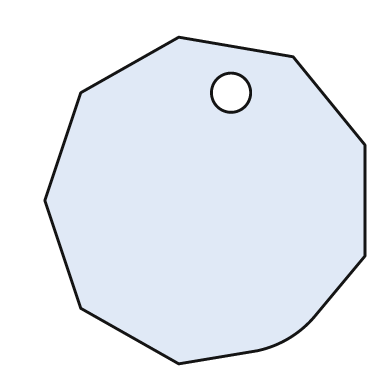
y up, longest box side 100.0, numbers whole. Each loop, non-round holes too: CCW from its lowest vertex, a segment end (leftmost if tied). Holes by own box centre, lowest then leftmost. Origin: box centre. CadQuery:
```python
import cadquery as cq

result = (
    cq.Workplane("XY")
    .moveTo(-8.0, -50.0)
    .lineTo(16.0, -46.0)
    .threePointArc((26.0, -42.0), (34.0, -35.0))
    .lineTo(49.0, -17.0)
    .lineTo(49.0, 17.0)
    .lineTo(27.0, 44.0)
    .lineTo(-8.0, 50.0)
    .lineTo(-38.0, 33.0)
    .lineTo(-49.0, 0.0)
    .lineTo(-38.0, -33.0)
    .close()
    .moveTo(8.0, 33.0)
    .circle(6.0)
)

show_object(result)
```